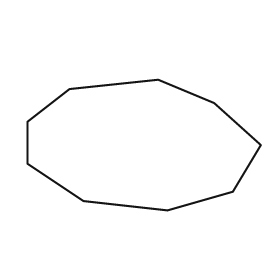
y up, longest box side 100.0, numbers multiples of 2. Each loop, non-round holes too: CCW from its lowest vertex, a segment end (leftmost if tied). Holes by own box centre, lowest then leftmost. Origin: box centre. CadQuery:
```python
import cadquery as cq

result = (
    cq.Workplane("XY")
    .moveTo(10.0, -28.0)
    .lineTo(38.0, -20.0)
    .lineTo(50.0, 0.0)
    .lineTo(30.0, 18.0)
    .lineTo(6.0, 28.0)
    .lineTo(-32.0, 24.0)
    .lineTo(-50.0, 10.0)
    .lineTo(-50.0, -8.0)
    .lineTo(-26.0, -24.0)
    .close()
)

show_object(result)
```